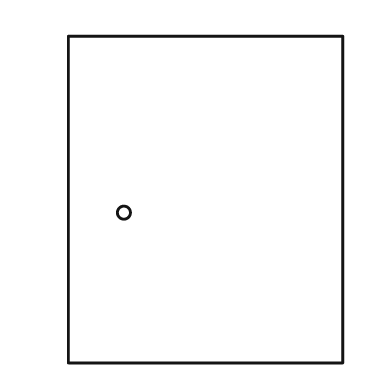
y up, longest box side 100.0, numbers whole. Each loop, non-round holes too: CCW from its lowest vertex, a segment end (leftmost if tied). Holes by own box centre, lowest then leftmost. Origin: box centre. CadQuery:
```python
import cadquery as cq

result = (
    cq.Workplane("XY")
    .moveTo(-42.0, -50.0)
    .lineTo(42.0, -50.0)
    .lineTo(42.0, 50.0)
    .lineTo(-42.0, 50.0)
    .close()
    .moveTo(-25.0, -4.0)
    .circle(2.0)
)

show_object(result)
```